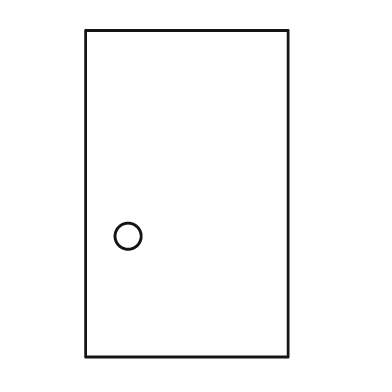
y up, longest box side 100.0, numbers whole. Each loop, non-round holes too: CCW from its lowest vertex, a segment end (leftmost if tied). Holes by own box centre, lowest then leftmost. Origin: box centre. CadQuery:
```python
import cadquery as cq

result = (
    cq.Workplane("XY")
    .moveTo(-31.0, -50.0)
    .lineTo(31.0, -50.0)
    .lineTo(31.0, 50.0)
    .lineTo(-31.0, 50.0)
    .close()
    .moveTo(-18.0, -13.0)
    .circle(4.0)
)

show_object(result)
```